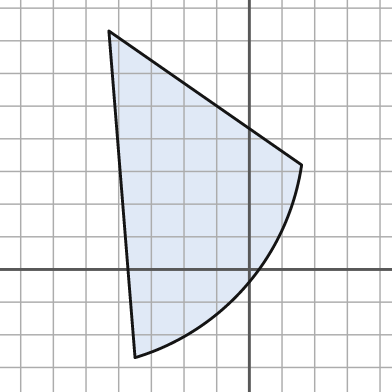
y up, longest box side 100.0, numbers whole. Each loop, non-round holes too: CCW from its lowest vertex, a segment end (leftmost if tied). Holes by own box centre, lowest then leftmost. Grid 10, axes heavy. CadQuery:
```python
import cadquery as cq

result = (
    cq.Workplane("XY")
    .moveTo(-35.0, -27.0)
    .threePointArc((-1.0, -5.0), (16.0, 32.0))
    .lineTo(-43.0, 73.0)
    .close()
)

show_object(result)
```